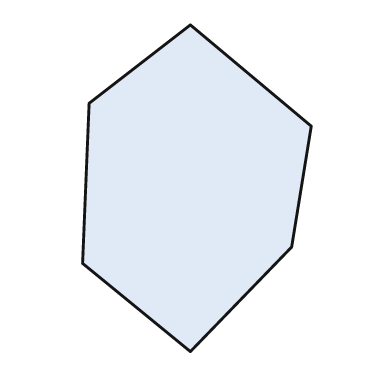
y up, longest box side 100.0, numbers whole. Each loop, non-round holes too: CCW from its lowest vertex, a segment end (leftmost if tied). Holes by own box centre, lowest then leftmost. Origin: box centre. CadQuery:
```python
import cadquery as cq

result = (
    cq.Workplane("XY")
    .moveTo(-2.0, -50.0)
    .lineTo(29.0, -18.0)
    .lineTo(35.0, 19.0)
    .lineTo(-2.0, 50.0)
    .lineTo(-33.0, 26.0)
    .lineTo(-35.0, -23.0)
    .close()
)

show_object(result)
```